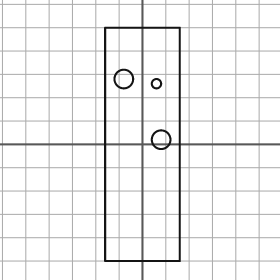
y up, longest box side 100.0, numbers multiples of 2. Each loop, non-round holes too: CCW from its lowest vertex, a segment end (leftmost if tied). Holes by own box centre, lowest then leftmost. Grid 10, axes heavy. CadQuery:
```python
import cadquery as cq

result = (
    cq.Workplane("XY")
    .moveTo(-16.0, -50.0)
    .lineTo(16.0, -50.0)
    .lineTo(16.0, 50.0)
    .lineTo(-16.0, 50.0)
    .close()
    .moveTo(8.0, 2.0)
    .circle(4.0)
    .moveTo(6.0, 26.0)
    .circle(2.0)
    .moveTo(-8.0, 28.0)
    .circle(4.0)
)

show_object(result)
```